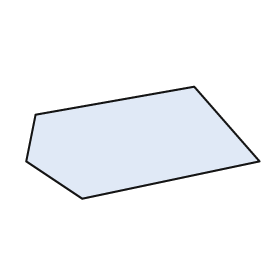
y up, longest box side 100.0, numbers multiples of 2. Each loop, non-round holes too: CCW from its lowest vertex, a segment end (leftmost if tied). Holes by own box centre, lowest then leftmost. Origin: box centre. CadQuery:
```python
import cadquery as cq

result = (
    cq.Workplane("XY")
    .moveTo(-26.0, -24.0)
    .lineTo(50.0, -8.0)
    .lineTo(22.0, 24.0)
    .lineTo(-46.0, 12.0)
    .lineTo(-50.0, -8.0)
    .close()
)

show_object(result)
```